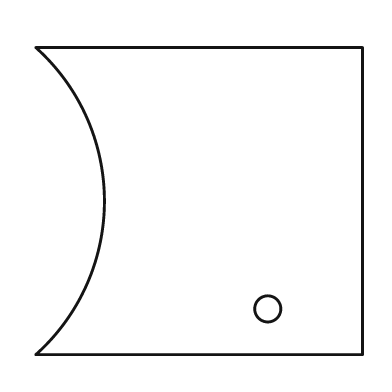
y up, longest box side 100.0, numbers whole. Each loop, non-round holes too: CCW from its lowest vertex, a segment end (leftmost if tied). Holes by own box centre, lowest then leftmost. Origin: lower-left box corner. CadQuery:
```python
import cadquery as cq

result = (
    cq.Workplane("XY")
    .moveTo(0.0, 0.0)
    .lineTo(100.0, 0.0)
    .lineTo(100.0, 94.0)
    .lineTo(0.0, 94.0)
    .threePointArc((21.0, 47.0), (0.0, 0.0))
    .close()
    .moveTo(71.0, 14.0)
    .circle(4.0)
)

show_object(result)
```